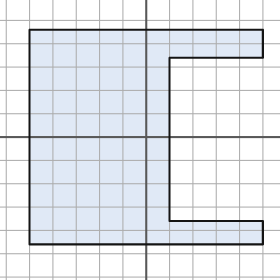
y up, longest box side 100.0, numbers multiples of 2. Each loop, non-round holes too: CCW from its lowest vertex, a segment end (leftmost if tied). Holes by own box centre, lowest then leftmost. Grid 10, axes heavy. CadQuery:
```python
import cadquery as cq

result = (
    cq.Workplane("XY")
    .moveTo(-50.0, -46.0)
    .lineTo(50.0, -46.0)
    .lineTo(50.0, -36.0)
    .lineTo(10.0, -36.0)
    .lineTo(10.0, 34.0)
    .lineTo(50.0, 34.0)
    .lineTo(50.0, 46.0)
    .lineTo(-50.0, 46.0)
    .close()
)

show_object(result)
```